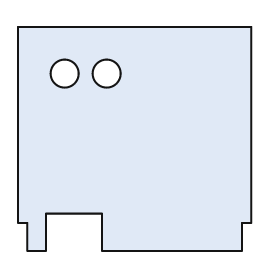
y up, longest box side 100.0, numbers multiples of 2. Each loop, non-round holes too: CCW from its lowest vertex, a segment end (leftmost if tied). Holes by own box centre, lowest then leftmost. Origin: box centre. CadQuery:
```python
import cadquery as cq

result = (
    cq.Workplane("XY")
    .moveTo(-46.0, -48.0)
    .lineTo(-38.0, -48.0)
    .lineTo(-38.0, -32.0)
    .lineTo(-14.0, -32.0)
    .lineTo(-14.0, -48.0)
    .lineTo(46.0, -48.0)
    .lineTo(46.0, -36.0)
    .lineTo(50.0, -36.0)
    .lineTo(50.0, 48.0)
    .lineTo(-50.0, 48.0)
    .lineTo(-50.0, -36.0)
    .lineTo(-46.0, -36.0)
    .close()
    .moveTo(-30.0, 28.0)
    .circle(6.0)
    .moveTo(-12.0, 28.0)
    .circle(6.0)
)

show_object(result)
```